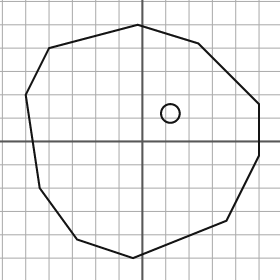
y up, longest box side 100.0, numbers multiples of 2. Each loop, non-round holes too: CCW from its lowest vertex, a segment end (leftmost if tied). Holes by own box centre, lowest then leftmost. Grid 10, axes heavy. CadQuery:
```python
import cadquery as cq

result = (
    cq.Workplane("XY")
    .moveTo(-4.0, -50.0)
    .lineTo(36.0, -34.0)
    .lineTo(50.0, -6.0)
    .lineTo(50.0, 16.0)
    .lineTo(24.0, 42.0)
    .lineTo(-2.0, 50.0)
    .lineTo(-40.0, 40.0)
    .lineTo(-50.0, 20.0)
    .lineTo(-44.0, -20.0)
    .lineTo(-28.0, -42.0)
    .close()
    .moveTo(12.0, 12.0)
    .circle(4.0)
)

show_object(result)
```